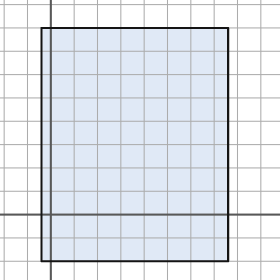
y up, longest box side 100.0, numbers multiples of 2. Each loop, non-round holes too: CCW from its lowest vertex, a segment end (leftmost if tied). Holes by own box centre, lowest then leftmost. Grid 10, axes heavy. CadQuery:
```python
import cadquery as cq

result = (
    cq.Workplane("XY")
    .moveTo(-4.0, -20.0)
    .lineTo(76.0, -20.0)
    .lineTo(76.0, 80.0)
    .lineTo(-4.0, 80.0)
    .close()
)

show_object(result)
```